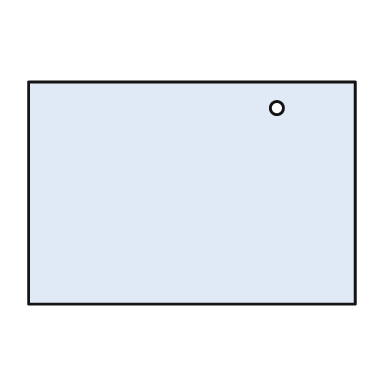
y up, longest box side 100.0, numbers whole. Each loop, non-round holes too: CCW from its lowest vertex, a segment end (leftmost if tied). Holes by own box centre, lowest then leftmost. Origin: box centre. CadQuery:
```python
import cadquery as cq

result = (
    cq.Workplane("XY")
    .moveTo(-50.0, -34.0)
    .lineTo(50.0, -34.0)
    .lineTo(50.0, 34.0)
    .lineTo(-50.0, 34.0)
    .close()
    .moveTo(26.0, 26.0)
    .circle(2.0)
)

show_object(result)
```